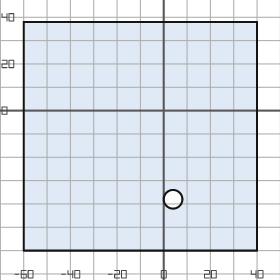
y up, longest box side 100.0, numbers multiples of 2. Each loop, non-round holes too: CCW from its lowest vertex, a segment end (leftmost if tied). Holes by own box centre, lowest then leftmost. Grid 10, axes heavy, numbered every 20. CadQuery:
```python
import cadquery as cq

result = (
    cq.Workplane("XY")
    .moveTo(-60.0, -60.0)
    .lineTo(40.0, -60.0)
    .lineTo(40.0, 38.0)
    .lineTo(-60.0, 38.0)
    .close()
    .moveTo(4.0, -38.0)
    .circle(4.0)
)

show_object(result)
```